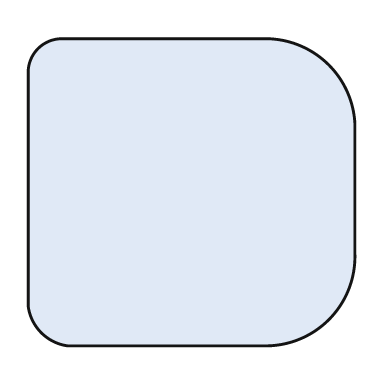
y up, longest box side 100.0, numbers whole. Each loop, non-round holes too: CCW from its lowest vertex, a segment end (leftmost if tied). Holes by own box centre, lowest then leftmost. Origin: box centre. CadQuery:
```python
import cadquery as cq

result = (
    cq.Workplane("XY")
    .moveTo(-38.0, -47.0)
    .lineTo(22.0, -47.0)
    .threePointArc((42.0, -39.0), (50.0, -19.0))
    .lineTo(50.0, 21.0)
    .threePointArc((42.0, 39.0), (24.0, 47.0))
    .lineTo(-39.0, 47.0)
    .threePointArc((-47.0, 44.0), (-50.0, 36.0))
    .lineTo(-50.0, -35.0)
    .threePointArc((-46.0, -43.0), (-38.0, -47.0))
    .close()
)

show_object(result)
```